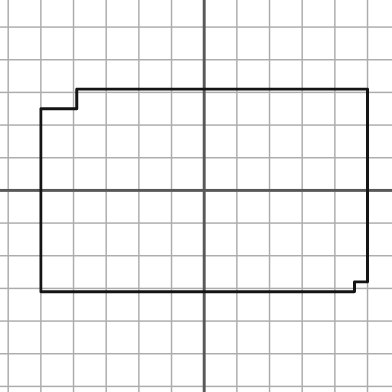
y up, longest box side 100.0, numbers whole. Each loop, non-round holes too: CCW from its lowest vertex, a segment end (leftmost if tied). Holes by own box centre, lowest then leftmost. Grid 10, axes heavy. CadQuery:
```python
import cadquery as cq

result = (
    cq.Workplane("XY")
    .moveTo(-50.0, -31.0)
    .lineTo(46.0, -31.0)
    .lineTo(46.0, -28.0)
    .lineTo(50.0, -28.0)
    .lineTo(50.0, 31.0)
    .lineTo(-39.0, 31.0)
    .lineTo(-39.0, 25.0)
    .lineTo(-50.0, 25.0)
    .close()
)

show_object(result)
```